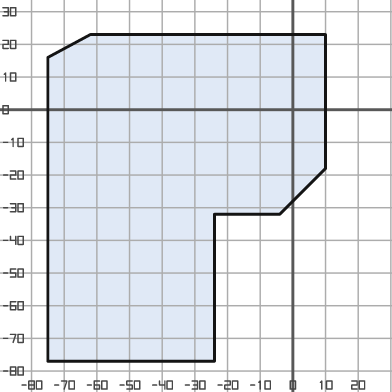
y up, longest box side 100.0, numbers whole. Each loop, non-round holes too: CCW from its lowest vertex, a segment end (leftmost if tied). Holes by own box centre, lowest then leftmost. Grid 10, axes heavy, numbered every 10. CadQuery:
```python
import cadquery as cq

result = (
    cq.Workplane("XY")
    .moveTo(-75.0, -77.0)
    .lineTo(-24.0, -77.0)
    .lineTo(-24.0, -32.0)
    .lineTo(-4.0, -32.0)
    .lineTo(10.0, -18.0)
    .lineTo(10.0, 23.0)
    .lineTo(-62.0, 23.0)
    .lineTo(-75.0, 16.0)
    .close()
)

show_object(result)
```